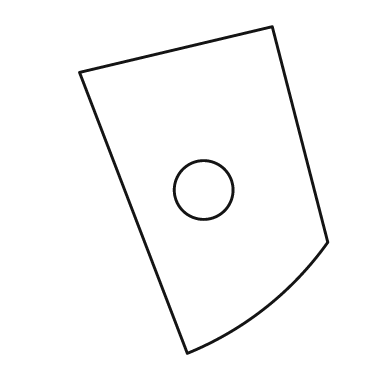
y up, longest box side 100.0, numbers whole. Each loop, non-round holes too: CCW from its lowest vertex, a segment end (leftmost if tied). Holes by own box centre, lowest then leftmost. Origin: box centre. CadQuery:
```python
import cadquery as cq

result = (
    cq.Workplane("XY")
    .moveTo(-5.0, -50.0)
    .threePointArc((19.0, -36.0), (38.0, -16.0))
    .lineTo(21.0, 50.0)
    .lineTo(-38.0, 36.0)
    .close()
    .moveTo(0.0, 0.0)
    .circle(9.0)
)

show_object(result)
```